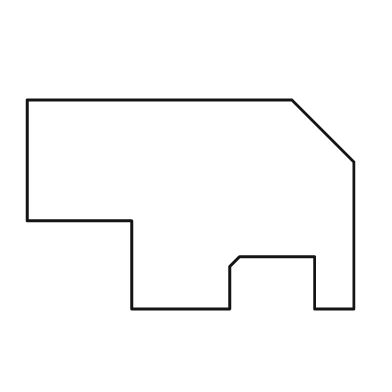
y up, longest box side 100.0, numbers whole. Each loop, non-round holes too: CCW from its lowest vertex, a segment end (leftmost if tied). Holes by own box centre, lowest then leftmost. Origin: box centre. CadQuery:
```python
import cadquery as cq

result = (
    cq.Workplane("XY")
    .moveTo(-18.0, -32.0)
    .lineTo(12.0, -32.0)
    .lineTo(12.0, -19.0)
    .lineTo(15.0, -16.0)
    .lineTo(38.0, -16.0)
    .lineTo(38.0, -32.0)
    .lineTo(50.0, -32.0)
    .lineTo(50.0, 13.0)
    .lineTo(31.0, 32.0)
    .lineTo(-50.0, 32.0)
    .lineTo(-50.0, -5.0)
    .lineTo(-18.0, -5.0)
    .close()
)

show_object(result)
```